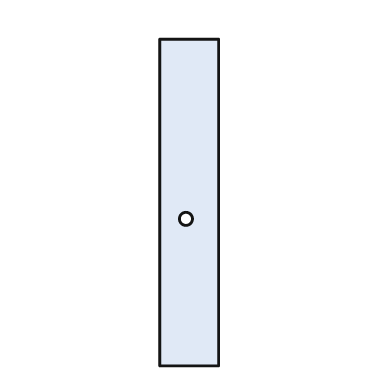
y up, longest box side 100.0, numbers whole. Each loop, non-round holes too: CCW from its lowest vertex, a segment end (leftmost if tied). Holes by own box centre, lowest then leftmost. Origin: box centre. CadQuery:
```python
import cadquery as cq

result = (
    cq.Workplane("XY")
    .moveTo(-9.0, -50.0)
    .lineTo(9.0, -50.0)
    .lineTo(9.0, 50.0)
    .lineTo(-9.0, 50.0)
    .close()
    .moveTo(-1.0, -5.0)
    .circle(2.0)
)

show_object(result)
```